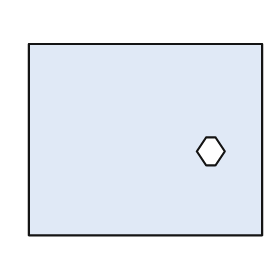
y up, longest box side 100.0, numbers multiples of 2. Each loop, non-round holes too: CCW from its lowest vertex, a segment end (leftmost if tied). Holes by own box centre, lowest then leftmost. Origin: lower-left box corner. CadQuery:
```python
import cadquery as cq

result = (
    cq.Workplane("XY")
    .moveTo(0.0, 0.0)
    .lineTo(100.0, 0.0)
    .lineTo(100.0, 82.0)
    .lineTo(0.0, 82.0)
    .close()
    .moveTo(76.0, 30.0)
    .lineTo(80.0, 30.0)
    .lineTo(84.0, 36.0)
    .lineTo(80.0, 42.0)
    .lineTo(76.0, 42.0)
    .lineTo(72.0, 36.0)
    .close()
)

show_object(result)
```